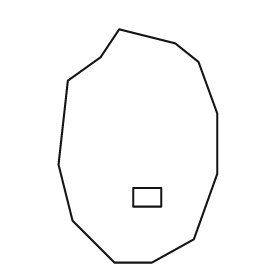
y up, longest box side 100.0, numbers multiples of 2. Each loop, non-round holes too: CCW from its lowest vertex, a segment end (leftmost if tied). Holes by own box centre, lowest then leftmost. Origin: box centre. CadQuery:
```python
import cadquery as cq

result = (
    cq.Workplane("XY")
    .moveTo(-10.0, -50.0)
    .lineTo(6.0, -50.0)
    .lineTo(24.0, -40.0)
    .lineTo(34.0, -12.0)
    .lineTo(34.0, 14.0)
    .lineTo(26.0, 36.0)
    .lineTo(16.0, 44.0)
    .lineTo(-8.0, 50.0)
    .lineTo(-16.0, 38.0)
    .lineTo(-30.0, 28.0)
    .lineTo(-34.0, -8.0)
    .lineTo(-28.0, -32.0)
    .close()
    .moveTo(-2.0, -26.0)
    .lineTo(10.0, -26.0)
    .lineTo(10.0, -18.0)
    .lineTo(-2.0, -18.0)
    .close()
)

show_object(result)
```